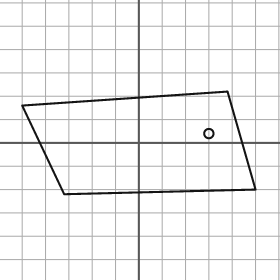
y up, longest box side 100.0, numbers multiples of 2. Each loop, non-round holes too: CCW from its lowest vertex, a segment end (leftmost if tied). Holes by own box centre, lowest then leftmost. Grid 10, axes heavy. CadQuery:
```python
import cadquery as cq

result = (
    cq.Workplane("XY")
    .moveTo(-32.0, -22.0)
    .lineTo(50.0, -20.0)
    .lineTo(38.0, 22.0)
    .lineTo(-50.0, 16.0)
    .close()
    .moveTo(30.0, 4.0)
    .circle(2.0)
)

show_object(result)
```